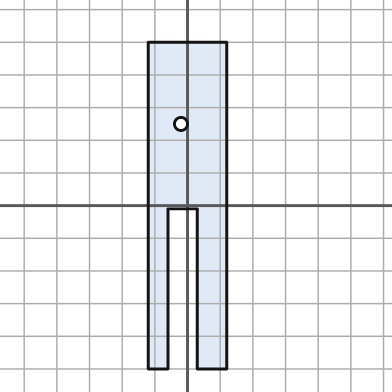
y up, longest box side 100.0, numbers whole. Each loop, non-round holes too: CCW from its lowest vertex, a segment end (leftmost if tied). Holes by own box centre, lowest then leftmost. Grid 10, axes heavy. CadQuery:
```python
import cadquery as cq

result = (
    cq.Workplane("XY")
    .moveTo(-12.0, -50.0)
    .lineTo(-6.0, -50.0)
    .lineTo(-6.0, -1.0)
    .lineTo(3.0, -1.0)
    .lineTo(3.0, -50.0)
    .lineTo(12.0, -50.0)
    .lineTo(12.0, 50.0)
    .lineTo(-12.0, 50.0)
    .close()
    .moveTo(-2.0, 25.0)
    .circle(2.0)
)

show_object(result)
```